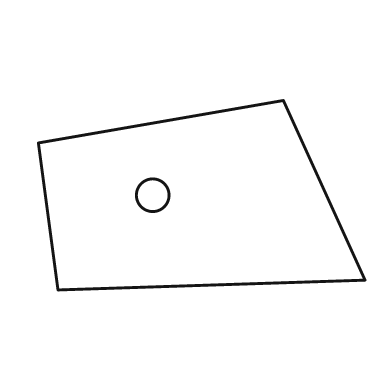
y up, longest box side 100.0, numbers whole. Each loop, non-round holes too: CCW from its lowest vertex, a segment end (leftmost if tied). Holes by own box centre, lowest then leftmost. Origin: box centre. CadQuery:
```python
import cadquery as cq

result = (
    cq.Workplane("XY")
    .moveTo(-44.0, -29.0)
    .lineTo(50.0, -26.0)
    .lineTo(25.0, 29.0)
    .lineTo(-50.0, 16.0)
    .close()
    .moveTo(-15.0, 0.0)
    .circle(5.0)
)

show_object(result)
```